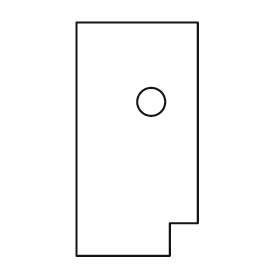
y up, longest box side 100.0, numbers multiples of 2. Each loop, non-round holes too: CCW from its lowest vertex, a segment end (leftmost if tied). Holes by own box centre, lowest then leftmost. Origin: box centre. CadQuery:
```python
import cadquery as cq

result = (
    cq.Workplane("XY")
    .moveTo(-26.0, -50.0)
    .lineTo(14.0, -50.0)
    .lineTo(14.0, -36.0)
    .lineTo(26.0, -36.0)
    .lineTo(26.0, 50.0)
    .lineTo(-26.0, 50.0)
    .close()
    .moveTo(6.0, 16.0)
    .circle(6.0)
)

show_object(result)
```